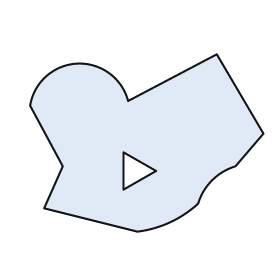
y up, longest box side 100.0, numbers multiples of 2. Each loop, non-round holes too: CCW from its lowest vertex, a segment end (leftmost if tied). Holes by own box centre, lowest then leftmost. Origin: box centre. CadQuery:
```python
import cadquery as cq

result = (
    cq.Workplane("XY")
    .moveTo(-4.0, -38.0)
    .threePointArc((10.0, -34.0), (22.0, -26.0))
    .threePointArc((28.0, -16.0), (38.0, -10.0))
    .lineTo(50.0, 4.0)
    .lineTo(30.0, 38.0)
    .lineTo(-8.0, 18.0)
    .threePointArc((-30.0, 34.0), (-50.0, 16.0))
    .lineTo(-36.0, -10.0)
    .lineTo(-44.0, -28.0)
    .close()
    .moveTo(-10.0, -20.0)
    .lineTo(4.0, -12.0)
    .lineTo(-10.0, -4.0)
    .close()
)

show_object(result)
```